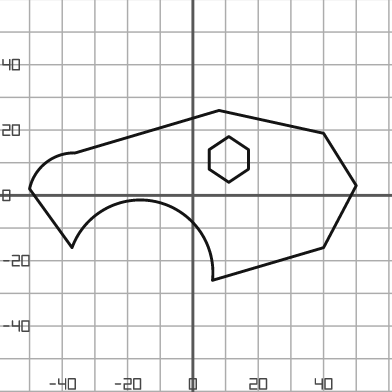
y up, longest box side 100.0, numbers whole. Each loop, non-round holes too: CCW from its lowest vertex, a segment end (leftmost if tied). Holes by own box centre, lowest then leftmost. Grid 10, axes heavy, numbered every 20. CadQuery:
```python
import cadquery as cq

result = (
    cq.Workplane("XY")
    .moveTo(6.0, -26.0)
    .lineTo(40.0, -16.0)
    .lineTo(50.0, 3.0)
    .lineTo(40.0, 19.0)
    .lineTo(8.0, 26.0)
    .lineTo(-36.0, 13.0)
    .threePointArc((-45.0, 10.0), (-50.0, 2.0))
    .lineTo(-37.0, -16.0)
    .threePointArc((-11.0, -2.0), (6.0, -26.0))
    .close()
    .moveTo(11.0, 4.0)
    .lineTo(17.0, 8.0)
    .lineTo(17.0, 14.0)
    .lineTo(11.0, 18.0)
    .lineTo(5.0, 14.0)
    .lineTo(5.0, 8.0)
    .close()
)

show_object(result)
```